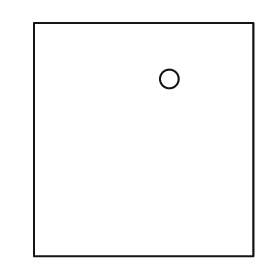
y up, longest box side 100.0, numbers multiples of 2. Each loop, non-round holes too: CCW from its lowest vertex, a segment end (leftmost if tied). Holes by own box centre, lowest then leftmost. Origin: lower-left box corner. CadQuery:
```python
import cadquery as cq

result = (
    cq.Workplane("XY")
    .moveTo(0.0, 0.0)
    .lineTo(94.0, 0.0)
    .lineTo(94.0, 100.0)
    .lineTo(0.0, 100.0)
    .close()
    .moveTo(58.0, 76.0)
    .circle(4.0)
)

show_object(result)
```